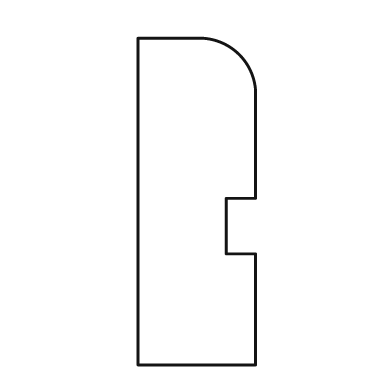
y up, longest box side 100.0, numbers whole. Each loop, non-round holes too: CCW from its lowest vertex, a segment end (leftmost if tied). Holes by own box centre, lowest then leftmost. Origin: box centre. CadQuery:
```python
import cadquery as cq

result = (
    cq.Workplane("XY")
    .moveTo(-18.0, -50.0)
    .lineTo(18.0, -50.0)
    .lineTo(18.0, -16.0)
    .lineTo(9.0, -16.0)
    .lineTo(9.0, 1.0)
    .lineTo(18.0, 1.0)
    .lineTo(18.0, 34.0)
    .threePointArc((13.0, 45.0), (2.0, 50.0))
    .lineTo(-18.0, 50.0)
    .close()
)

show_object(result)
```